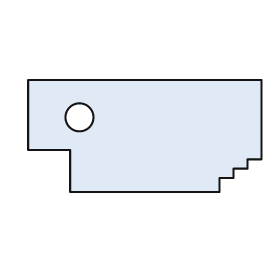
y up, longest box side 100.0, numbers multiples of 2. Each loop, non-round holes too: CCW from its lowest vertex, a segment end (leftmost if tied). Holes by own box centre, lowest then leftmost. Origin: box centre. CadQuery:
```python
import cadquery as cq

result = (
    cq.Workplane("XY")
    .moveTo(-32.0, -24.0)
    .lineTo(32.0, -24.0)
    .lineTo(32.0, -18.0)
    .lineTo(38.0, -18.0)
    .lineTo(38.0, -14.0)
    .lineTo(44.0, -14.0)
    .lineTo(44.0, -10.0)
    .lineTo(50.0, -10.0)
    .lineTo(50.0, 24.0)
    .lineTo(-50.0, 24.0)
    .lineTo(-50.0, -6.0)
    .lineTo(-32.0, -6.0)
    .close()
    .moveTo(-28.0, 8.0)
    .circle(6.0)
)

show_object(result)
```